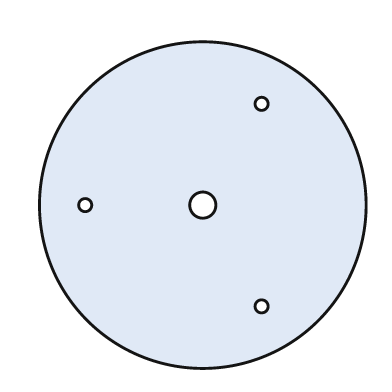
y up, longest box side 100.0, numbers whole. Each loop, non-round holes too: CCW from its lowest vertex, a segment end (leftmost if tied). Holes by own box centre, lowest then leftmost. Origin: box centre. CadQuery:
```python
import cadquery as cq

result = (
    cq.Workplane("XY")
    .moveTo(0.0, 0.0)
    .circle(50.0)
    .moveTo(18.0, -31.0)
    .circle(2.0)
    .moveTo(-36.0, 0.0)
    .circle(2.0)
    .moveTo(0.0, 0.0)
    .circle(4.0)
    .moveTo(18.0, 31.0)
    .circle(2.0)
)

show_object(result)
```